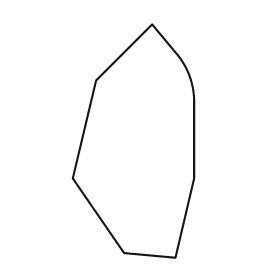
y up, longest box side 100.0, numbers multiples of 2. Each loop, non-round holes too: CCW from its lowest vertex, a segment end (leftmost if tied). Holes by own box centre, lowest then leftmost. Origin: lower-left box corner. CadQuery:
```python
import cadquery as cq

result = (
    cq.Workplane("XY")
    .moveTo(44.0, 0.0)
    .lineTo(52.0, 34.0)
    .lineTo(52.0, 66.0)
    .threePointArc((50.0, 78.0), (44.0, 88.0))
    .lineTo(34.0, 100.0)
    .lineTo(10.0, 76.0)
    .lineTo(0.0, 34.0)
    .lineTo(22.0, 2.0)
    .close()
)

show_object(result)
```